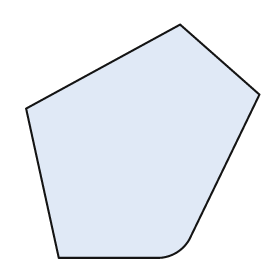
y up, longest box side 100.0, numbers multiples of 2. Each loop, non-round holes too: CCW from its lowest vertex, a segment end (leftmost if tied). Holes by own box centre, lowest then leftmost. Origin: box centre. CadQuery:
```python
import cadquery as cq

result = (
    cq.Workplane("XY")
    .moveTo(-36.0, -50.0)
    .lineTo(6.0, -50.0)
    .threePointArc((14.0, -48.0), (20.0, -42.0))
    .lineTo(50.0, 20.0)
    .lineTo(16.0, 50.0)
    .lineTo(-50.0, 14.0)
    .close()
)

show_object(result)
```